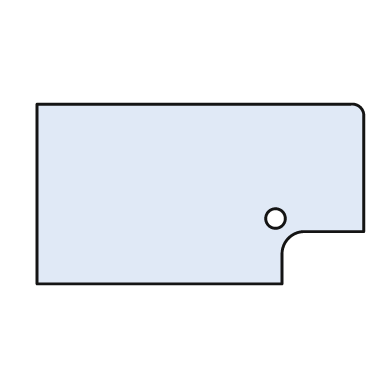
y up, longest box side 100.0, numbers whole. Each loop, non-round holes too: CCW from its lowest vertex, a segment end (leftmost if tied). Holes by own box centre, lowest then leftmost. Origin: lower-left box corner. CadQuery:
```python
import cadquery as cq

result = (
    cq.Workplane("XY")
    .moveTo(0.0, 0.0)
    .lineTo(75.0, 0.0)
    .lineTo(75.0, 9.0)
    .threePointArc((77.0, 14.0), (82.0, 16.0))
    .lineTo(100.0, 16.0)
    .lineTo(100.0, 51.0)
    .threePointArc((99.0, 54.0), (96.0, 55.0))
    .lineTo(0.0, 55.0)
    .close()
    .moveTo(73.0, 20.0)
    .circle(3.0)
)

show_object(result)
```